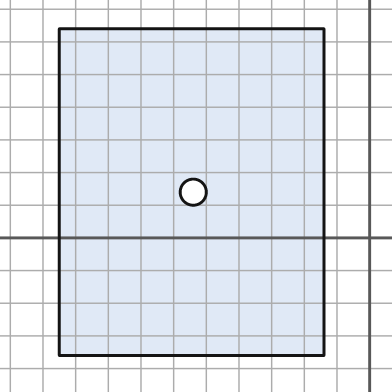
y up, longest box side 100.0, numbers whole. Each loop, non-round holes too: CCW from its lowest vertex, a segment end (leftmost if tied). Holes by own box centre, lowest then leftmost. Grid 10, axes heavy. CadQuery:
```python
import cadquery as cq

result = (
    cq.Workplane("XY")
    .moveTo(-95.0, -36.0)
    .lineTo(-14.0, -36.0)
    .lineTo(-14.0, 64.0)
    .lineTo(-95.0, 64.0)
    .close()
    .moveTo(-54.0, 14.0)
    .circle(4.0)
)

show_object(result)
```